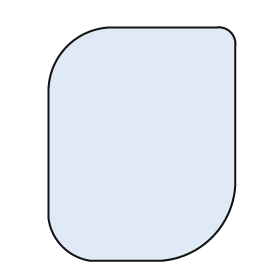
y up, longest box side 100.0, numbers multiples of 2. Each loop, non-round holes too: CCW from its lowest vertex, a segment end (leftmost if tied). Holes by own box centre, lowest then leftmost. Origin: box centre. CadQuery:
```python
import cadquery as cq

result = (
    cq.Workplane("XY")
    .moveTo(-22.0, -50.0)
    .lineTo(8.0, -50.0)
    .threePointArc((30.0, -40.0), (40.0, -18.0))
    .lineTo(40.0, 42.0)
    .threePointArc((38.0, 48.0), (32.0, 50.0))
    .lineTo(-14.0, 50.0)
    .threePointArc((-32.0, 42.0), (-40.0, 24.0))
    .lineTo(-40.0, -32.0)
    .threePointArc((-34.0, -44.0), (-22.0, -50.0))
    .close()
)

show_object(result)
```